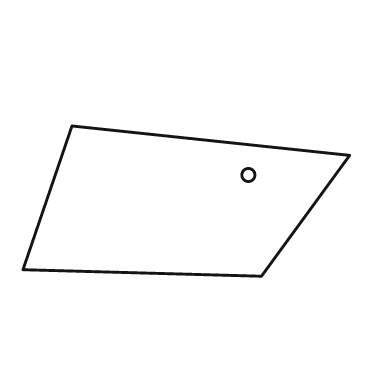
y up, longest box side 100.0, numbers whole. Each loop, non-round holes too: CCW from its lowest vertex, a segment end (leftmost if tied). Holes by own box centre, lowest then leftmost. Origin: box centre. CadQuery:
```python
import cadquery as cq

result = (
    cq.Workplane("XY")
    .moveTo(23.0, -23.0)
    .lineTo(50.0, 14.0)
    .lineTo(-35.0, 23.0)
    .lineTo(-50.0, -21.0)
    .close()
    .moveTo(19.0, 8.0)
    .circle(2.0)
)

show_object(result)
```